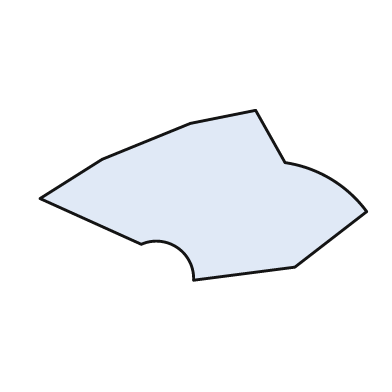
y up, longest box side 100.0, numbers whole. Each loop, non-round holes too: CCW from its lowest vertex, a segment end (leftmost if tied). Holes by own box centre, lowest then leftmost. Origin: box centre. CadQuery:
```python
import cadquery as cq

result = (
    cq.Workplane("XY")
    .moveTo(-3.0, -26.0)
    .lineTo(28.0, -22.0)
    .lineTo(50.0, -5.0)
    .threePointArc((39.0, 5.0), (25.0, 10.0))
    .lineTo(16.0, 26.0)
    .lineTo(-4.0, 22.0)
    .lineTo(-31.0, 11.0)
    .lineTo(-50.0, -1.0)
    .lineTo(-19.0, -15.0)
    .threePointArc((-8.0, -16.0), (-3.0, -26.0))
    .close()
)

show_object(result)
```